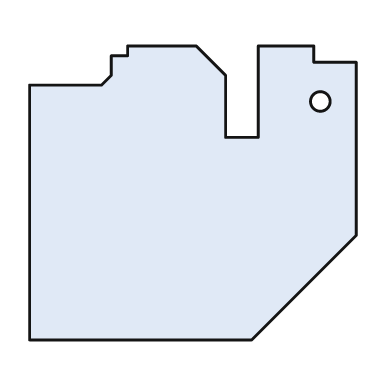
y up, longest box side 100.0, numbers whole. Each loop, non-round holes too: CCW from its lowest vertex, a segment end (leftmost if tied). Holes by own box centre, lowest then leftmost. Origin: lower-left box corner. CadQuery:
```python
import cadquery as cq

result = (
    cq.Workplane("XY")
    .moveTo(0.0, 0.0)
    .lineTo(68.0, 0.0)
    .lineTo(100.0, 32.0)
    .lineTo(100.0, 85.0)
    .lineTo(87.0, 85.0)
    .lineTo(87.0, 90.0)
    .lineTo(70.0, 90.0)
    .lineTo(70.0, 62.0)
    .lineTo(60.0, 62.0)
    .lineTo(60.0, 81.0)
    .lineTo(51.0, 90.0)
    .lineTo(30.0, 90.0)
    .lineTo(30.0, 87.0)
    .lineTo(25.0, 87.0)
    .lineTo(25.0, 81.0)
    .lineTo(22.0, 78.0)
    .lineTo(0.0, 78.0)
    .close()
    .moveTo(89.0, 73.0)
    .circle(3.0)
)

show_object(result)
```